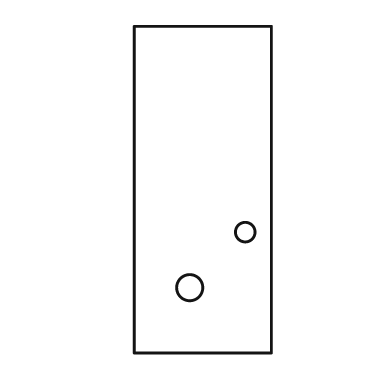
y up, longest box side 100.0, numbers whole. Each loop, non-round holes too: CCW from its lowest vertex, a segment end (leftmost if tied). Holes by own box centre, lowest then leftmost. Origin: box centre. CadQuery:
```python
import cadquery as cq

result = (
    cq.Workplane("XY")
    .moveTo(-21.0, -50.0)
    .lineTo(21.0, -50.0)
    .lineTo(21.0, 50.0)
    .lineTo(-21.0, 50.0)
    .close()
    .moveTo(-4.0, -30.0)
    .circle(4.0)
    .moveTo(13.0, -13.0)
    .circle(3.0)
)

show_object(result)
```